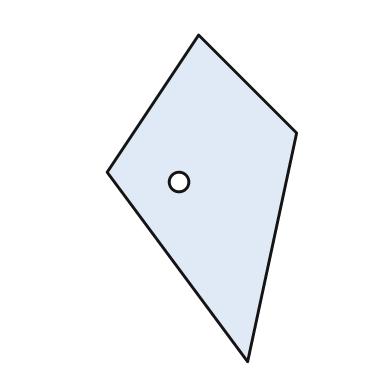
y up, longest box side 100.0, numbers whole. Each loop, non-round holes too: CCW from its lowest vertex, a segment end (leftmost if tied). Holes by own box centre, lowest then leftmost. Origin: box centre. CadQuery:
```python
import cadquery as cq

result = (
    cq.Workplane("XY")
    .moveTo(14.0, -50.0)
    .lineTo(29.0, 20.0)
    .lineTo(-1.0, 50.0)
    .lineTo(-29.0, 8.0)
    .close()
    .moveTo(-7.0, 5.0)
    .circle(3.0)
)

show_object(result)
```